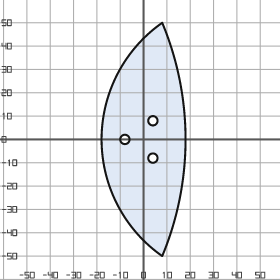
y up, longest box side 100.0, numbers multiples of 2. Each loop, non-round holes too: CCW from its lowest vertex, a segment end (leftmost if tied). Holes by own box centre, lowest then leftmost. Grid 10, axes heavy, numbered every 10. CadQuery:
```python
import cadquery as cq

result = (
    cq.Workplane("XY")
    .moveTo(8.0, -50.0)
    .threePointArc((18.0, 0.0), (8.0, 50.0))
    .threePointArc((-18.0, 0.0), (8.0, -50.0))
    .close()
    .moveTo(4.0, -8.0)
    .circle(2.0)
    .moveTo(-8.0, 0.0)
    .circle(2.0)
    .moveTo(4.0, 8.0)
    .circle(2.0)
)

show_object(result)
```